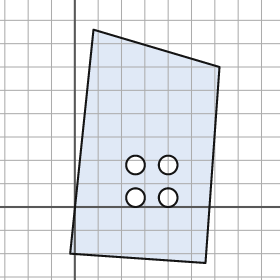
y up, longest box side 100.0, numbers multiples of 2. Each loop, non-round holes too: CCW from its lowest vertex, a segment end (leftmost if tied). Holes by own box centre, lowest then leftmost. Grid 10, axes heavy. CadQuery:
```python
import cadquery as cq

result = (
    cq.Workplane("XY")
    .moveTo(56.0, -24.0)
    .lineTo(62.0, 60.0)
    .lineTo(8.0, 76.0)
    .lineTo(-2.0, -20.0)
    .close()
    .moveTo(26.0, 4.0)
    .circle(4.0)
    .moveTo(40.0, 4.0)
    .circle(4.0)
    .moveTo(26.0, 18.0)
    .circle(4.0)
    .moveTo(40.0, 18.0)
    .circle(4.0)
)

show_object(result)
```